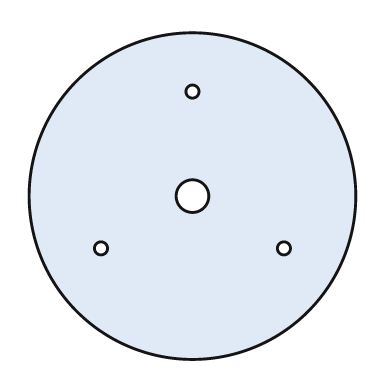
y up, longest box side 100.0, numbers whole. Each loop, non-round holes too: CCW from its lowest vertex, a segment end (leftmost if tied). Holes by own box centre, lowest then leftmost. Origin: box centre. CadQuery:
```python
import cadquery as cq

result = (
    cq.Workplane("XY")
    .moveTo(0.0, 0.0)
    .circle(50.0)
    .moveTo(-28.0, -16.0)
    .circle(2.0)
    .moveTo(28.0, -16.0)
    .circle(2.0)
    .moveTo(0.0, 0.0)
    .circle(5.0)
    .moveTo(0.0, 32.0)
    .circle(2.0)
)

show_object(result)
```